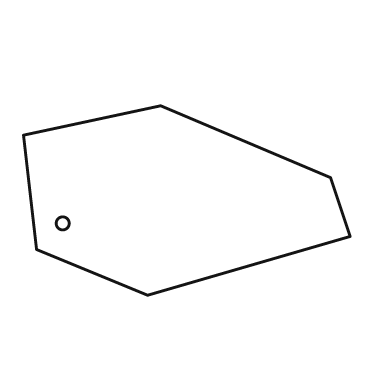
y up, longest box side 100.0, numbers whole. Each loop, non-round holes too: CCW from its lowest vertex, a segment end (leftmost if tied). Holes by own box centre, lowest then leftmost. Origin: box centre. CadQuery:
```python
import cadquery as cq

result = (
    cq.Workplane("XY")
    .moveTo(-12.0, -29.0)
    .lineTo(50.0, -11.0)
    .lineTo(44.0, 7.0)
    .lineTo(-8.0, 29.0)
    .lineTo(-50.0, 20.0)
    .lineTo(-46.0, -15.0)
    .close()
    .moveTo(-38.0, -7.0)
    .circle(2.0)
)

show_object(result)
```